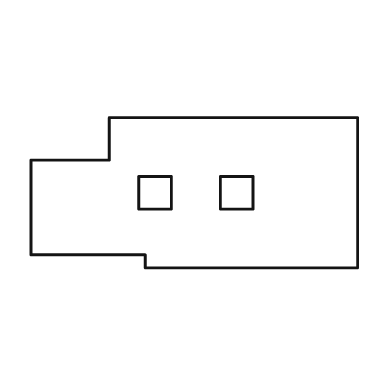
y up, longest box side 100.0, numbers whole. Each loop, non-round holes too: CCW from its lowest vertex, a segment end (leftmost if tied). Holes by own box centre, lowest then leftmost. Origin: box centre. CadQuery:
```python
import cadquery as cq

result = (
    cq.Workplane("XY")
    .moveTo(-15.0, -23.0)
    .lineTo(50.0, -23.0)
    .lineTo(50.0, 23.0)
    .lineTo(-26.0, 23.0)
    .lineTo(-26.0, 10.0)
    .lineTo(-50.0, 10.0)
    .lineTo(-50.0, -19.0)
    .lineTo(-15.0, -19.0)
    .close()
    .moveTo(-17.0, -5.0)
    .lineTo(-7.0, -5.0)
    .lineTo(-7.0, 5.0)
    .lineTo(-17.0, 5.0)
    .close()
    .moveTo(8.0, -5.0)
    .lineTo(18.0, -5.0)
    .lineTo(18.0, 5.0)
    .lineTo(8.0, 5.0)
    .close()
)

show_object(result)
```